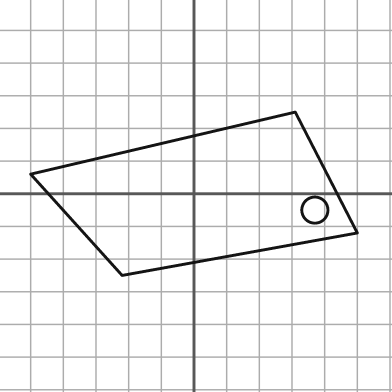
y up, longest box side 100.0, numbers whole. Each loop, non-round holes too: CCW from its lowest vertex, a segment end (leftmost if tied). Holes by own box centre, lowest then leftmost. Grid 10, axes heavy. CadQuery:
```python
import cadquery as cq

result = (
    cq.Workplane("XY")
    .moveTo(-22.0, -25.0)
    .lineTo(50.0, -12.0)
    .lineTo(31.0, 25.0)
    .lineTo(-50.0, 6.0)
    .close()
    .moveTo(37.0, -5.0)
    .circle(4.0)
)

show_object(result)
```